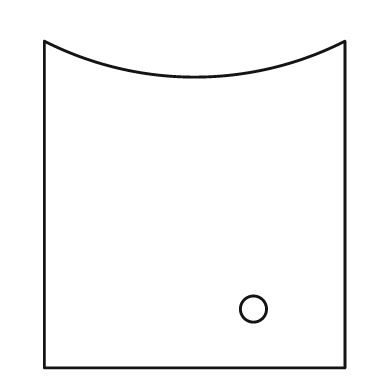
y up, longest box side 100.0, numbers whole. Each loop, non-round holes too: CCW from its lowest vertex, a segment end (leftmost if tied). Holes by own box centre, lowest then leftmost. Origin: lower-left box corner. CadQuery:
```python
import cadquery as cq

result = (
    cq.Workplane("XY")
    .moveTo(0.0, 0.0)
    .lineTo(92.0, 0.0)
    .lineTo(92.0, 100.0)
    .threePointArc((46.0, 89.0), (0.0, 100.0))
    .close()
    .moveTo(64.0, 18.0)
    .circle(4.0)
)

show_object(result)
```